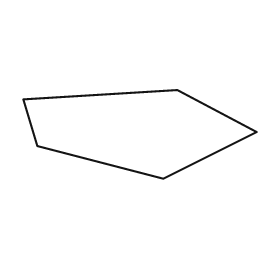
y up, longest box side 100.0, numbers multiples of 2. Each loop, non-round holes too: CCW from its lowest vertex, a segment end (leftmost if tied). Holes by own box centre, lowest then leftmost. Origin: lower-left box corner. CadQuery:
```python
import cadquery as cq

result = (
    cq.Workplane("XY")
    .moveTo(60.0, 0.0)
    .lineTo(100.0, 20.0)
    .lineTo(66.0, 38.0)
    .lineTo(0.0, 34.0)
    .lineTo(6.0, 14.0)
    .close()
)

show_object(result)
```